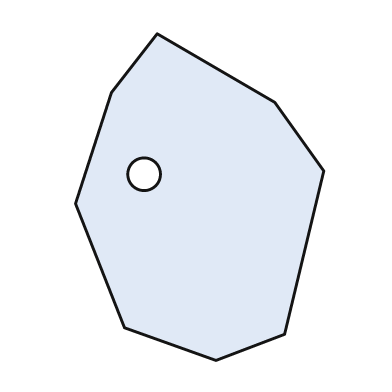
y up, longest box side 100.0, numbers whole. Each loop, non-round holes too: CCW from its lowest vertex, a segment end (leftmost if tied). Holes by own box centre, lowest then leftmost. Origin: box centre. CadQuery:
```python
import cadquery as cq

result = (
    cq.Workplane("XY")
    .moveTo(5.0, -50.0)
    .lineTo(26.0, -42.0)
    .lineTo(38.0, 8.0)
    .lineTo(23.0, 29.0)
    .lineTo(-13.0, 50.0)
    .lineTo(-27.0, 32.0)
    .lineTo(-38.0, -2.0)
    .lineTo(-23.0, -40.0)
    .close()
    .moveTo(-17.0, 7.0)
    .circle(5.0)
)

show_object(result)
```